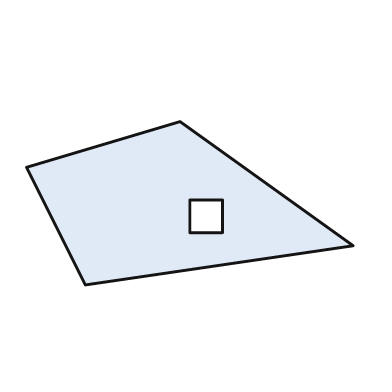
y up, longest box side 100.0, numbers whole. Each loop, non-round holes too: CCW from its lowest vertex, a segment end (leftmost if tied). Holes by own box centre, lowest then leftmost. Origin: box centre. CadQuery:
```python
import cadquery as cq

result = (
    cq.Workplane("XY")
    .moveTo(-32.0, -25.0)
    .lineTo(50.0, -13.0)
    .lineTo(-3.0, 25.0)
    .lineTo(-50.0, 11.0)
    .close()
    .moveTo(0.0, -9.0)
    .lineTo(10.0, -9.0)
    .lineTo(10.0, 1.0)
    .lineTo(0.0, 1.0)
    .close()
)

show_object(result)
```